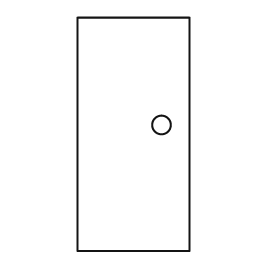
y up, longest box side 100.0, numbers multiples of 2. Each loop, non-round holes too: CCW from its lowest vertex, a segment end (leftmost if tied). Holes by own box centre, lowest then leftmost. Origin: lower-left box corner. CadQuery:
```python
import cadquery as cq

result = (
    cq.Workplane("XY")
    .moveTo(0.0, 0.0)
    .lineTo(48.0, 0.0)
    .lineTo(48.0, 100.0)
    .lineTo(0.0, 100.0)
    .close()
    .moveTo(36.0, 54.0)
    .circle(4.0)
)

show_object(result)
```